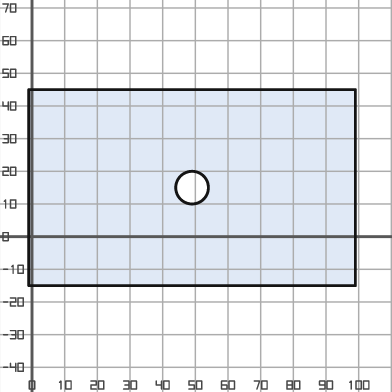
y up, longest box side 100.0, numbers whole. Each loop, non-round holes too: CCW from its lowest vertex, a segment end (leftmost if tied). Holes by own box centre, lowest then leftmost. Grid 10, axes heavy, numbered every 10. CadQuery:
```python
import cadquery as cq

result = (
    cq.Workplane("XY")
    .moveTo(-1.0, -15.0)
    .lineTo(99.0, -15.0)
    .lineTo(99.0, 45.0)
    .lineTo(-1.0, 45.0)
    .close()
    .moveTo(49.0, 15.0)
    .circle(5.0)
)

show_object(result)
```